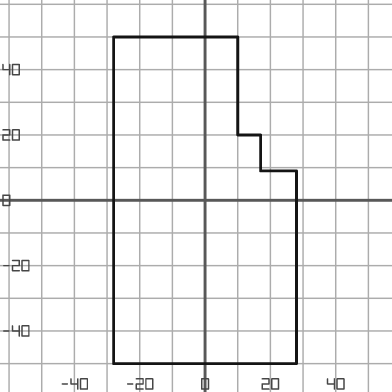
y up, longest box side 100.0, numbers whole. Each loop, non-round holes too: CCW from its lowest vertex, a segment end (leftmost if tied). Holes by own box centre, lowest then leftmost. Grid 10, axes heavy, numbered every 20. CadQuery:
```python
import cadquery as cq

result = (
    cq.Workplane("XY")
    .moveTo(-28.0, -50.0)
    .lineTo(28.0, -50.0)
    .lineTo(28.0, 9.0)
    .lineTo(17.0, 9.0)
    .lineTo(17.0, 20.0)
    .lineTo(10.0, 20.0)
    .lineTo(10.0, 50.0)
    .lineTo(-28.0, 50.0)
    .close()
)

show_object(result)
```